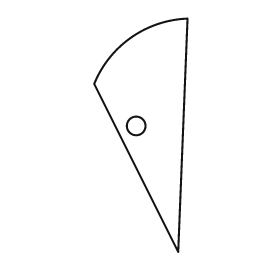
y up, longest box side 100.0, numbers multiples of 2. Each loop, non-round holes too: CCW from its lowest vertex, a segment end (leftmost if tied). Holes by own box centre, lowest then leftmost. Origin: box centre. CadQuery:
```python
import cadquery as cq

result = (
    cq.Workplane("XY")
    .moveTo(16.0, -50.0)
    .lineTo(20.0, 50.0)
    .threePointArc((-4.0, 42.0), (-20.0, 22.0))
    .close()
    .moveTo(-2.0, 4.0)
    .circle(4.0)
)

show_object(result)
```